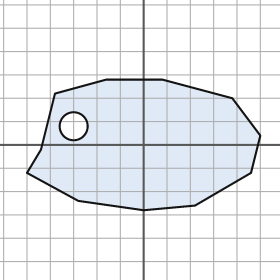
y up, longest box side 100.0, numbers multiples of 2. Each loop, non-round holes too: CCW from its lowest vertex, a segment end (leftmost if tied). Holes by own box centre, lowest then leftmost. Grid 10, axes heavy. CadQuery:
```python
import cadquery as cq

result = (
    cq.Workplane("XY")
    .moveTo(0.0, -28.0)
    .lineTo(22.0, -26.0)
    .lineTo(46.0, -12.0)
    .lineTo(50.0, 4.0)
    .lineTo(38.0, 20.0)
    .lineTo(8.0, 28.0)
    .lineTo(-16.0, 28.0)
    .lineTo(-38.0, 22.0)
    .lineTo(-44.0, -2.0)
    .lineTo(-50.0, -12.0)
    .lineTo(-28.0, -24.0)
    .close()
    .moveTo(-30.0, 8.0)
    .circle(6.0)
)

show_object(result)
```